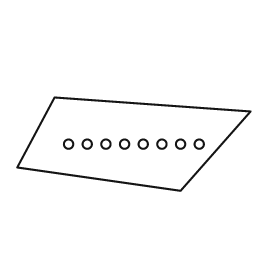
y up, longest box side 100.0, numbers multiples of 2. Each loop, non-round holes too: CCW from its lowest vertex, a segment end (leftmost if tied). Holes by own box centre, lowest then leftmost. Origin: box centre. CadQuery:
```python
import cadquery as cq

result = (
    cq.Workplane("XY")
    .moveTo(20.0, -20.0)
    .lineTo(50.0, 14.0)
    .lineTo(-34.0, 20.0)
    .lineTo(-50.0, -10.0)
    .close()
    .moveTo(-28.0, 0.0)
    .circle(2.0)
    .moveTo(-20.0, 0.0)
    .circle(2.0)
    .moveTo(-12.0, 0.0)
    .circle(2.0)
    .moveTo(-4.0, 0.0)
    .circle(2.0)
    .moveTo(4.0, 0.0)
    .circle(2.0)
    .moveTo(12.0, 0.0)
    .circle(2.0)
    .moveTo(20.0, 0.0)
    .circle(2.0)
    .moveTo(28.0, 0.0)
    .circle(2.0)
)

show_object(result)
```